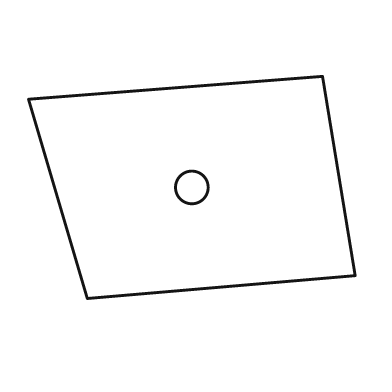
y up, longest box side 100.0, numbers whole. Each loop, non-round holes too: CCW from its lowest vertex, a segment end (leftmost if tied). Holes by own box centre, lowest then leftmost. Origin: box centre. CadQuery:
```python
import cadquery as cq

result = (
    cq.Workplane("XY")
    .moveTo(-32.0, -34.0)
    .lineTo(50.0, -27.0)
    .lineTo(40.0, 34.0)
    .lineTo(-50.0, 27.0)
    .close()
    .moveTo(0.0, 0.0)
    .circle(5.0)
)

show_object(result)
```